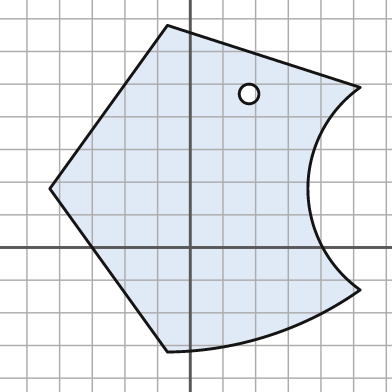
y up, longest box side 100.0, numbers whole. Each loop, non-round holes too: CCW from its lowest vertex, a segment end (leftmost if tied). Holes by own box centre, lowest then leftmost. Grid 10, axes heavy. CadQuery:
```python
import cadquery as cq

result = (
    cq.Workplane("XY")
    .moveTo(-7.0, -32.0)
    .threePointArc((24.0, -27.0), (52.0, -13.0))
    .threePointArc((36.0, 18.0), (52.0, 49.0))
    .lineTo(-7.0, 68.0)
    .lineTo(-43.0, 18.0)
    .close()
    .moveTo(18.0, 47.0)
    .circle(3.0)
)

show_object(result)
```